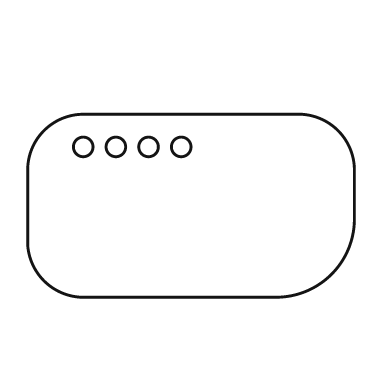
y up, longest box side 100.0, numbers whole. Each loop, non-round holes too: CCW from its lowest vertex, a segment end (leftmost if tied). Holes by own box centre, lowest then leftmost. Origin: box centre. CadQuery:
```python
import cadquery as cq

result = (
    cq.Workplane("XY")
    .moveTo(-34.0, -28.0)
    .lineTo(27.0, -28.0)
    .threePointArc((43.0, -21.0), (50.0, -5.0))
    .lineTo(50.0, 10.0)
    .threePointArc((45.0, 23.0), (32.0, 28.0))
    .lineTo(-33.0, 28.0)
    .threePointArc((-45.0, 23.0), (-50.0, 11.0))
    .lineTo(-50.0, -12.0)
    .threePointArc((-45.0, -23.0), (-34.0, -28.0))
    .close()
    .moveTo(-33.0, 18.0)
    .circle(3.0)
    .moveTo(-23.0, 18.0)
    .circle(3.0)
    .moveTo(-13.0, 18.0)
    .circle(3.0)
    .moveTo(-3.0, 18.0)
    .circle(3.0)
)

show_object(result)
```